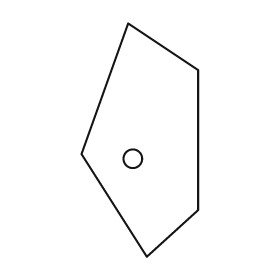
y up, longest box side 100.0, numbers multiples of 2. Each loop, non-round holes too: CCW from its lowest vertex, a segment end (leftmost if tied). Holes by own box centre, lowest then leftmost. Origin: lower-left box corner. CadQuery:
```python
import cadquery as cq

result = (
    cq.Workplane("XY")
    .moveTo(28.0, 0.0)
    .lineTo(50.0, 20.0)
    .lineTo(50.0, 80.0)
    .lineTo(20.0, 100.0)
    .lineTo(0.0, 44.0)
    .close()
    .moveTo(22.0, 42.0)
    .circle(4.0)
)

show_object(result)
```